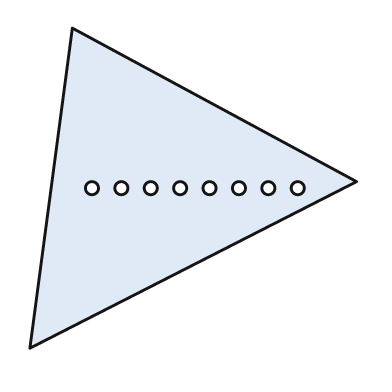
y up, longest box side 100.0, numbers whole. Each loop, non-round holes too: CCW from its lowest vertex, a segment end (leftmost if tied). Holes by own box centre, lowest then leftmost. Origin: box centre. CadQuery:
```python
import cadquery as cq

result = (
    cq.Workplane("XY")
    .moveTo(-50.0, -49.0)
    .lineTo(50.0, 2.0)
    .lineTo(-37.0, 49.0)
    .close()
    .moveTo(-31.0, 0.0)
    .circle(2.0)
    .moveTo(-22.0, 0.0)
    .circle(2.0)
    .moveTo(-13.0, 0.0)
    .circle(2.0)
    .moveTo(-4.0, 0.0)
    .circle(2.0)
    .moveTo(5.0, 0.0)
    .circle(2.0)
    .moveTo(14.0, 0.0)
    .circle(2.0)
    .moveTo(23.0, 0.0)
    .circle(2.0)
    .moveTo(32.0, 0.0)
    .circle(2.0)
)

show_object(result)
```